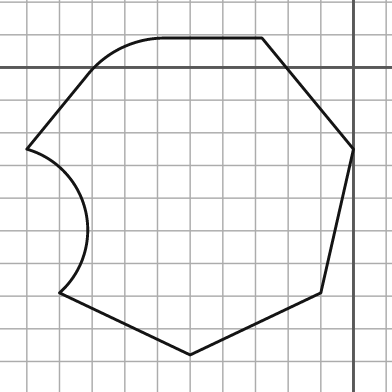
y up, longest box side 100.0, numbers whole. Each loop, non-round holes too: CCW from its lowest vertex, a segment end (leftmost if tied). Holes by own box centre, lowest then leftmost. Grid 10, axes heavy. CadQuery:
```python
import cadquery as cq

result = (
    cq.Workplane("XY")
    .moveTo(-50.0, -88.0)
    .lineTo(-10.0, -69.0)
    .lineTo(0.0, -25.0)
    .lineTo(-28.0, 9.0)
    .lineTo(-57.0, 9.0)
    .threePointArc((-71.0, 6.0), (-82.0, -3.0))
    .lineTo(-100.0, -25.0)
    .threePointArc((-82.0, -44.0), (-90.0, -69.0))
    .close()
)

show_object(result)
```